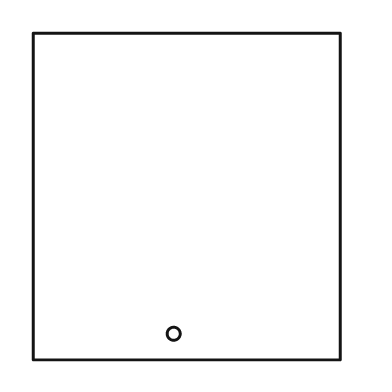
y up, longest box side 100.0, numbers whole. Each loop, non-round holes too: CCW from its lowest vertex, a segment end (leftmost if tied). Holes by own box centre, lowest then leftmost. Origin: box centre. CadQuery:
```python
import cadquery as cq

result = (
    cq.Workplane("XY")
    .moveTo(-47.0, -50.0)
    .lineTo(47.0, -50.0)
    .lineTo(47.0, 50.0)
    .lineTo(-47.0, 50.0)
    .close()
    .moveTo(-4.0, -42.0)
    .circle(2.0)
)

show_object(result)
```